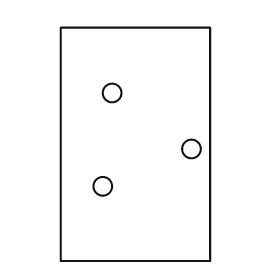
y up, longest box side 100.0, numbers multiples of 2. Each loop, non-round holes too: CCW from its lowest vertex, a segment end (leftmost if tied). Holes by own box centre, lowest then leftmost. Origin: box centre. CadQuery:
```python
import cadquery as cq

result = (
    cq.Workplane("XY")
    .moveTo(-32.0, -50.0)
    .lineTo(32.0, -50.0)
    .lineTo(32.0, 50.0)
    .lineTo(-32.0, 50.0)
    .close()
    .moveTo(-14.0, -18.0)
    .circle(4.0)
    .moveTo(24.0, -2.0)
    .circle(4.0)
    .moveTo(-10.0, 22.0)
    .circle(4.0)
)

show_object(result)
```